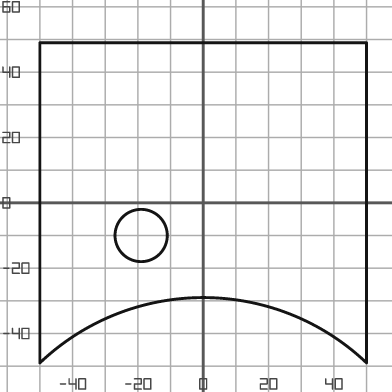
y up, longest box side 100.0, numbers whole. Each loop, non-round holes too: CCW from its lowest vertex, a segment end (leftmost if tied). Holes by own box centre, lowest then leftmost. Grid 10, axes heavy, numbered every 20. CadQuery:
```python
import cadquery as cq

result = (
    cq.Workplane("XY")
    .moveTo(-50.0, -49.0)
    .threePointArc((0.0, -29.0), (50.0, -49.0))
    .lineTo(50.0, 49.0)
    .lineTo(-50.0, 49.0)
    .close()
    .moveTo(-19.0, -10.0)
    .circle(8.0)
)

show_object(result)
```